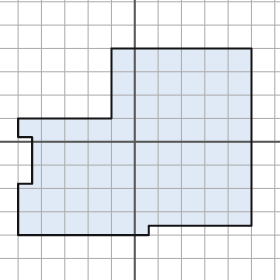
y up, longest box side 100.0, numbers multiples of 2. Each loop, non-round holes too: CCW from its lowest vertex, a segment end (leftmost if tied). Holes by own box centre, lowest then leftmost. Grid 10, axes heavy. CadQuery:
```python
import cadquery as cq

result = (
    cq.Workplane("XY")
    .moveTo(-50.0, -40.0)
    .lineTo(6.0, -40.0)
    .lineTo(6.0, -36.0)
    .lineTo(50.0, -36.0)
    .lineTo(50.0, 40.0)
    .lineTo(-10.0, 40.0)
    .lineTo(-10.0, 10.0)
    .lineTo(-50.0, 10.0)
    .lineTo(-50.0, 2.0)
    .lineTo(-44.0, 2.0)
    .lineTo(-44.0, -18.0)
    .lineTo(-50.0, -18.0)
    .close()
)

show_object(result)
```